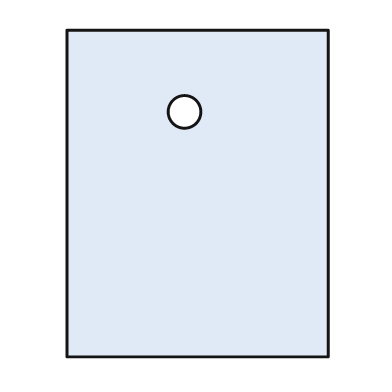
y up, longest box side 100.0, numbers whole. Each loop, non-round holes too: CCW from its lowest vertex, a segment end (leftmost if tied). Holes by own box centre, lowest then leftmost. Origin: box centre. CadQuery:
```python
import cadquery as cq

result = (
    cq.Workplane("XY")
    .moveTo(-40.0, -50.0)
    .lineTo(40.0, -50.0)
    .lineTo(40.0, 50.0)
    .lineTo(-40.0, 50.0)
    .close()
    .moveTo(-4.0, 25.0)
    .circle(5.0)
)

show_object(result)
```